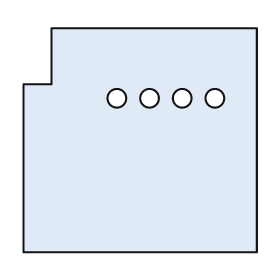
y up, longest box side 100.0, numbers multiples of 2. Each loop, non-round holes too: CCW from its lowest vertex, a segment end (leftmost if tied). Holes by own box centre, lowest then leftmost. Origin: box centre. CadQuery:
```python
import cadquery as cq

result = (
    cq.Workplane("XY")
    .moveTo(-50.0, -48.0)
    .lineTo(50.0, -48.0)
    .lineTo(50.0, 48.0)
    .lineTo(-38.0, 48.0)
    .lineTo(-38.0, 24.0)
    .lineTo(-50.0, 24.0)
    .close()
    .moveTo(-10.0, 18.0)
    .circle(4.0)
    .moveTo(4.0, 18.0)
    .circle(4.0)
    .moveTo(18.0, 18.0)
    .circle(4.0)
    .moveTo(32.0, 18.0)
    .circle(4.0)
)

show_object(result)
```